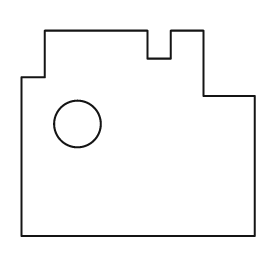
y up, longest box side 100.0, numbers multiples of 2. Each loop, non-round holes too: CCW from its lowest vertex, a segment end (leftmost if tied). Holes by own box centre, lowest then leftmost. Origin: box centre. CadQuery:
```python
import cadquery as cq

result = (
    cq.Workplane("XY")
    .moveTo(-50.0, -44.0)
    .lineTo(50.0, -44.0)
    .lineTo(50.0, 16.0)
    .lineTo(28.0, 16.0)
    .lineTo(28.0, 44.0)
    .lineTo(14.0, 44.0)
    .lineTo(14.0, 32.0)
    .lineTo(4.0, 32.0)
    .lineTo(4.0, 44.0)
    .lineTo(-40.0, 44.0)
    .lineTo(-40.0, 24.0)
    .lineTo(-50.0, 24.0)
    .close()
    .moveTo(-26.0, 4.0)
    .circle(10.0)
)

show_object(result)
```